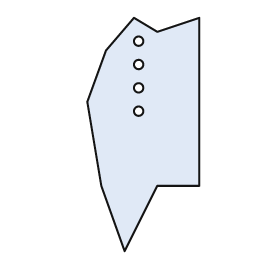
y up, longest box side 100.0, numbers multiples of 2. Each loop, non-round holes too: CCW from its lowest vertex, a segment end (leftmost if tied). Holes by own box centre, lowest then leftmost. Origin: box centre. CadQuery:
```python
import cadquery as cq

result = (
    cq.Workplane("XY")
    .moveTo(-8.0, -50.0)
    .lineTo(6.0, -22.0)
    .lineTo(24.0, -22.0)
    .lineTo(24.0, 50.0)
    .lineTo(6.0, 44.0)
    .lineTo(-4.0, 50.0)
    .lineTo(-16.0, 36.0)
    .lineTo(-24.0, 14.0)
    .lineTo(-18.0, -22.0)
    .close()
    .moveTo(-2.0, 10.0)
    .circle(2.0)
    .moveTo(-2.0, 20.0)
    .circle(2.0)
    .moveTo(-2.0, 30.0)
    .circle(2.0)
    .moveTo(-2.0, 40.0)
    .circle(2.0)
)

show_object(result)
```